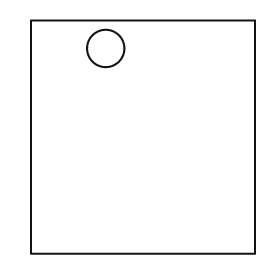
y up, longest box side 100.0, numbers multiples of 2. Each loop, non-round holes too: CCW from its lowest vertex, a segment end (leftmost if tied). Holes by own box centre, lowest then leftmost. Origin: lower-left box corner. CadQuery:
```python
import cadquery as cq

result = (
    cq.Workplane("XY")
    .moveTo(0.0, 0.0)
    .lineTo(96.0, 0.0)
    .lineTo(96.0, 100.0)
    .lineTo(0.0, 100.0)
    .close()
    .moveTo(32.0, 88.0)
    .circle(8.0)
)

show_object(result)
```